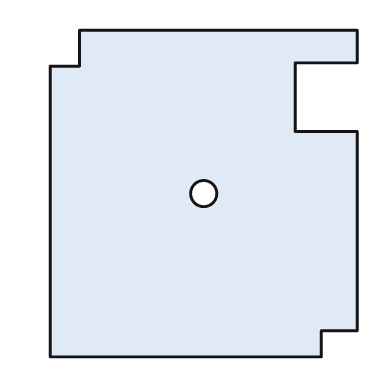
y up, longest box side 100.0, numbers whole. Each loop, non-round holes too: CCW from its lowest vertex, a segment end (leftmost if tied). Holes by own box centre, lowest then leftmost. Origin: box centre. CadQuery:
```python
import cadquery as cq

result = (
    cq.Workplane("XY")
    .moveTo(-47.0, -50.0)
    .lineTo(36.0, -50.0)
    .lineTo(36.0, -42.0)
    .lineTo(47.0, -42.0)
    .lineTo(47.0, 19.0)
    .lineTo(28.0, 19.0)
    .lineTo(28.0, 40.0)
    .lineTo(47.0, 40.0)
    .lineTo(47.0, 50.0)
    .lineTo(-38.0, 50.0)
    .lineTo(-38.0, 39.0)
    .lineTo(-47.0, 39.0)
    .close()
    .moveTo(0.0, 0.0)
    .circle(4.0)
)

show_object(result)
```